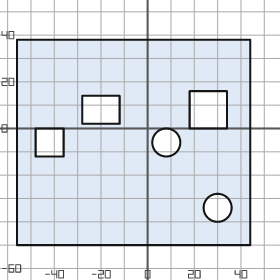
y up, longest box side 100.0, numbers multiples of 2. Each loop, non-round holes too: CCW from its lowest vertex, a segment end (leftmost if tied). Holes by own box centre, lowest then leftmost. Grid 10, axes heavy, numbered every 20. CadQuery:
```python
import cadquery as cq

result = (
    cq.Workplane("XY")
    .moveTo(-56.0, -50.0)
    .lineTo(44.0, -50.0)
    .lineTo(44.0, 38.0)
    .lineTo(-56.0, 38.0)
    .close()
    .moveTo(30.0, -34.0)
    .circle(6.0)
    .moveTo(-48.0, -12.0)
    .lineTo(-36.0, -12.0)
    .lineTo(-36.0, 0.0)
    .lineTo(-48.0, 0.0)
    .close()
    .moveTo(8.0, -6.0)
    .circle(6.0)
    .moveTo(-28.0, 2.0)
    .lineTo(-12.0, 2.0)
    .lineTo(-12.0, 14.0)
    .lineTo(-28.0, 14.0)
    .close()
    .moveTo(18.0, 0.0)
    .lineTo(34.0, 0.0)
    .lineTo(34.0, 16.0)
    .lineTo(18.0, 16.0)
    .close()
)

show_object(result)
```